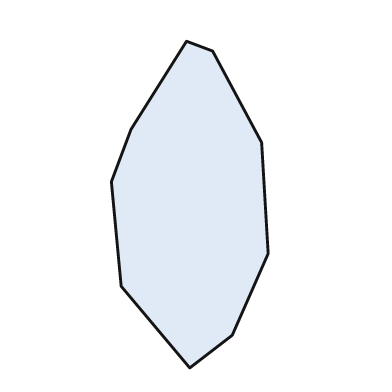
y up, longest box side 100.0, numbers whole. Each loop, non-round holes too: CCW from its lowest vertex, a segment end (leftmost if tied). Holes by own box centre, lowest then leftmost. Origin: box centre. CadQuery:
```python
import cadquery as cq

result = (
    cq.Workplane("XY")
    .moveTo(0.0, -50.0)
    .lineTo(13.0, -40.0)
    .lineTo(24.0, -15.0)
    .lineTo(22.0, 19.0)
    .lineTo(7.0, 47.0)
    .lineTo(-1.0, 50.0)
    .lineTo(-18.0, 23.0)
    .lineTo(-24.0, 7.0)
    .lineTo(-21.0, -25.0)
    .close()
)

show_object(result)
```